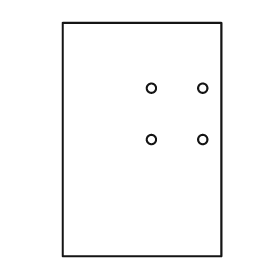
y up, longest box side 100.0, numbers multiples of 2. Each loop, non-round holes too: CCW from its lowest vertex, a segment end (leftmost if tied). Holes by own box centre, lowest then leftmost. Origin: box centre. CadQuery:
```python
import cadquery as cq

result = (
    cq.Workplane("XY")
    .moveTo(-34.0, -50.0)
    .lineTo(34.0, -50.0)
    .lineTo(34.0, 50.0)
    .lineTo(-34.0, 50.0)
    .close()
    .moveTo(4.0, 0.0)
    .circle(2.0)
    .moveTo(26.0, 0.0)
    .circle(2.0)
    .moveTo(4.0, 22.0)
    .circle(2.0)
    .moveTo(26.0, 22.0)
    .circle(2.0)
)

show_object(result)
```